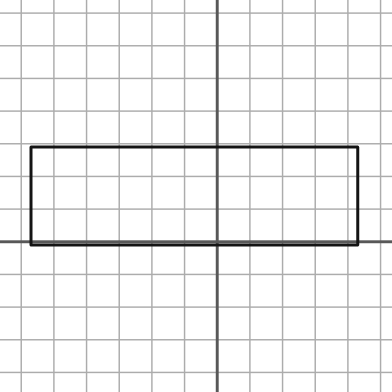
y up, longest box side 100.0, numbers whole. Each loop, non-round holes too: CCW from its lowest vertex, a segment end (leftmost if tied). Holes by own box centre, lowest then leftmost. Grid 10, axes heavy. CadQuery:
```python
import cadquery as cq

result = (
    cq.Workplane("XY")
    .moveTo(-57.0, -1.0)
    .lineTo(43.0, -1.0)
    .lineTo(43.0, 29.0)
    .lineTo(-57.0, 29.0)
    .close()
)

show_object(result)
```